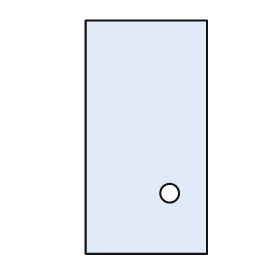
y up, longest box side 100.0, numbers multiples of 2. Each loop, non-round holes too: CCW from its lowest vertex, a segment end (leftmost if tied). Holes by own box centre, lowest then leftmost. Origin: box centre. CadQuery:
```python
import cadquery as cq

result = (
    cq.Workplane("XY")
    .moveTo(-26.0, -50.0)
    .lineTo(26.0, -50.0)
    .lineTo(26.0, 50.0)
    .lineTo(-26.0, 50.0)
    .close()
    .moveTo(10.0, -24.0)
    .circle(4.0)
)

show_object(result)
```